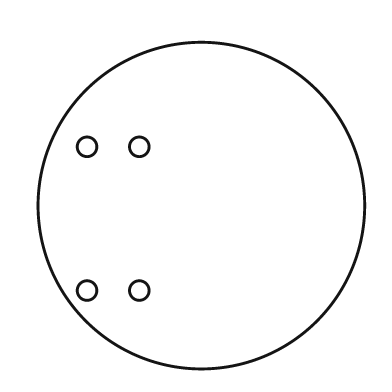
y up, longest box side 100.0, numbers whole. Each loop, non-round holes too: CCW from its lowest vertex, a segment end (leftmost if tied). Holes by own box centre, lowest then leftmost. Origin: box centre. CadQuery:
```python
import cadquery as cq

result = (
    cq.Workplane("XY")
    .moveTo(0.0, 0.0)
    .circle(50.0)
    .moveTo(-35.0, -26.0)
    .circle(3.0)
    .moveTo(-19.0, -26.0)
    .circle(3.0)
    .moveTo(-35.0, 18.0)
    .circle(3.0)
    .moveTo(-19.0, 18.0)
    .circle(3.0)
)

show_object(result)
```